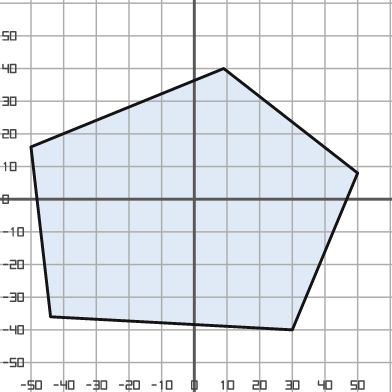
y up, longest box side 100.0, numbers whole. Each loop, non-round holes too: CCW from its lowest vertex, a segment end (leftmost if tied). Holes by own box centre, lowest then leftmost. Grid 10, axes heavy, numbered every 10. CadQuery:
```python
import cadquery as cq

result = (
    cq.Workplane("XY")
    .moveTo(30.0, -40.0)
    .lineTo(50.0, 8.0)
    .lineTo(9.0, 40.0)
    .lineTo(-50.0, 16.0)
    .lineTo(-44.0, -36.0)
    .close()
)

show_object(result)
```